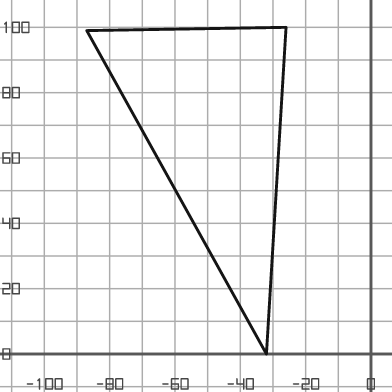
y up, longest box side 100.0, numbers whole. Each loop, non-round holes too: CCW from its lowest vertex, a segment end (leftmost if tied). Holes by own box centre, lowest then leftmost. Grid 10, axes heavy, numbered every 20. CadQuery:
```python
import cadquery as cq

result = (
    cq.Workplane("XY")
    .moveTo(-32.0, 0.0)
    .lineTo(-26.0, 100.0)
    .lineTo(-87.0, 99.0)
    .close()
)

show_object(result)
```